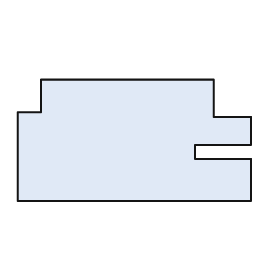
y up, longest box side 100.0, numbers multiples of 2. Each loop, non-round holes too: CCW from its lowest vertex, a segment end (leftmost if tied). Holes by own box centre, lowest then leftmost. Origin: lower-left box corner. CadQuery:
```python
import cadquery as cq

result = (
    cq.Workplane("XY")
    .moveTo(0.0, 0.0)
    .lineTo(100.0, 0.0)
    .lineTo(100.0, 18.0)
    .lineTo(76.0, 18.0)
    .lineTo(76.0, 24.0)
    .lineTo(100.0, 24.0)
    .lineTo(100.0, 36.0)
    .lineTo(84.0, 36.0)
    .lineTo(84.0, 52.0)
    .lineTo(10.0, 52.0)
    .lineTo(10.0, 38.0)
    .lineTo(0.0, 38.0)
    .close()
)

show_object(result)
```